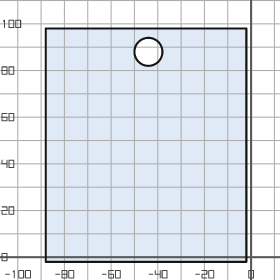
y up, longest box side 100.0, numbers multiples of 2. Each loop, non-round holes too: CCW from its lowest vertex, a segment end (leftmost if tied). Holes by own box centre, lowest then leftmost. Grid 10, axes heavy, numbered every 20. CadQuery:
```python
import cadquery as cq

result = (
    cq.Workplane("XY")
    .moveTo(-88.0, -2.0)
    .lineTo(-2.0, -2.0)
    .lineTo(-2.0, 98.0)
    .lineTo(-88.0, 98.0)
    .close()
    .moveTo(-44.0, 88.0)
    .circle(6.0)
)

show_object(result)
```